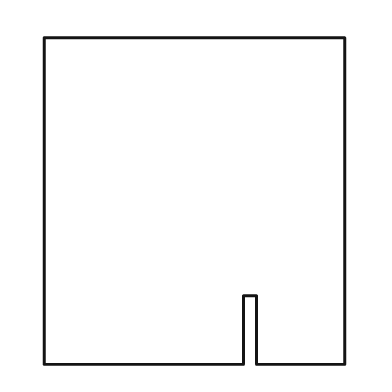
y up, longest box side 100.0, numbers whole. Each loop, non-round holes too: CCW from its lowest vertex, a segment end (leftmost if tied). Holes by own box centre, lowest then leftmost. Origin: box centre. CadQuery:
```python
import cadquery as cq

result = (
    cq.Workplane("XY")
    .moveTo(-46.0, -50.0)
    .lineTo(15.0, -50.0)
    .lineTo(15.0, -29.0)
    .lineTo(19.0, -29.0)
    .lineTo(19.0, -50.0)
    .lineTo(46.0, -50.0)
    .lineTo(46.0, 50.0)
    .lineTo(-46.0, 50.0)
    .close()
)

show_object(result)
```